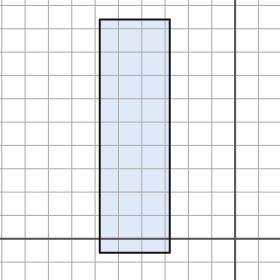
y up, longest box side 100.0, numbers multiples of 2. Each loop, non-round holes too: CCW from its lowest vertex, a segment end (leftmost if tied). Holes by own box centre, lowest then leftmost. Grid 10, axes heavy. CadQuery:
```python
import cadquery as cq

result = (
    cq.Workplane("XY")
    .moveTo(-58.0, -6.0)
    .lineTo(-28.0, -6.0)
    .lineTo(-28.0, 94.0)
    .lineTo(-58.0, 94.0)
    .close()
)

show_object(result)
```